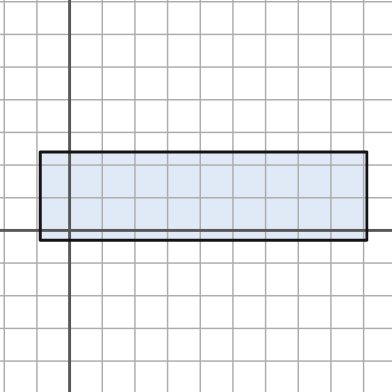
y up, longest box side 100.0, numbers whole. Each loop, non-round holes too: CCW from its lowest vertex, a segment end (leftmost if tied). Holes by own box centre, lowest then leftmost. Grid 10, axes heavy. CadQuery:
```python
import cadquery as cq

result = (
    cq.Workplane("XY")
    .moveTo(-9.0, -3.0)
    .lineTo(91.0, -3.0)
    .lineTo(91.0, 24.0)
    .lineTo(-9.0, 24.0)
    .close()
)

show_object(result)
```